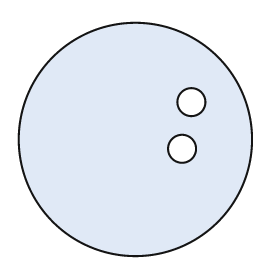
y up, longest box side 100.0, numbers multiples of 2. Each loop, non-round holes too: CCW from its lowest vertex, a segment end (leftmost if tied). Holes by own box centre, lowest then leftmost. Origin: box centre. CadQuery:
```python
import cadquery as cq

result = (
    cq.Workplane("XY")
    .moveTo(0.0, 0.0)
    .circle(50.0)
    .moveTo(20.0, -4.0)
    .circle(6.0)
    .moveTo(24.0, 16.0)
    .circle(6.0)
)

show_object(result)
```